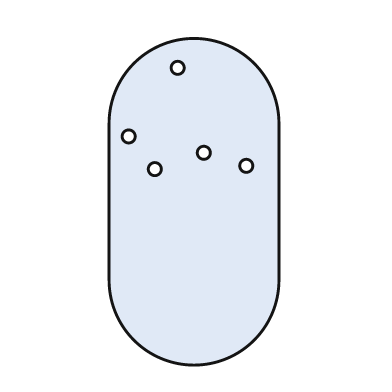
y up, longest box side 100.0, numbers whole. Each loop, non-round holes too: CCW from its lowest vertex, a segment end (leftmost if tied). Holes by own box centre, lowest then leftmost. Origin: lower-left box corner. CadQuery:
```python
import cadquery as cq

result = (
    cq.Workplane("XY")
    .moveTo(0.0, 26.0)
    .threePointArc((26.0, 0.0), (52.0, 26.0))
    .lineTo(52.0, 74.0)
    .threePointArc((26.0, 100.0), (0.0, 74.0))
    .close()
    .moveTo(14.0, 60.0)
    .circle(2.0)
    .moveTo(42.0, 61.0)
    .circle(2.0)
    .moveTo(29.0, 65.0)
    .circle(2.0)
    .moveTo(6.0, 70.0)
    .circle(2.0)
    .moveTo(21.0, 91.0)
    .circle(2.0)
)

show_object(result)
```